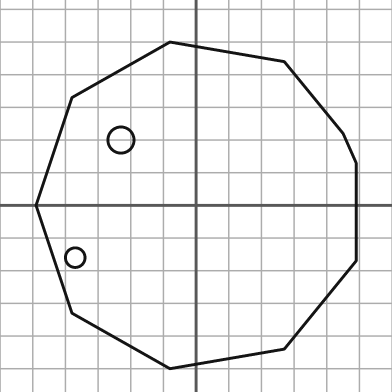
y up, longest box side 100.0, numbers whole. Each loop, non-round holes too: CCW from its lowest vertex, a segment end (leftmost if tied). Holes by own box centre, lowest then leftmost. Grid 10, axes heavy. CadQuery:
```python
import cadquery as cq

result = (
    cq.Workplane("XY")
    .moveTo(-8.0, -50.0)
    .lineTo(27.0, -44.0)
    .lineTo(49.0, -17.0)
    .lineTo(49.0, 13.0)
    .lineTo(45.0, 22.0)
    .lineTo(27.0, 44.0)
    .lineTo(-8.0, 50.0)
    .lineTo(-38.0, 33.0)
    .lineTo(-49.0, 0.0)
    .lineTo(-38.0, -33.0)
    .close()
    .moveTo(-37.0, -16.0)
    .circle(3.0)
    .moveTo(-23.0, 20.0)
    .circle(4.0)
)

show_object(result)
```